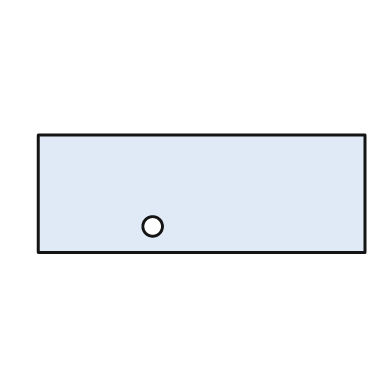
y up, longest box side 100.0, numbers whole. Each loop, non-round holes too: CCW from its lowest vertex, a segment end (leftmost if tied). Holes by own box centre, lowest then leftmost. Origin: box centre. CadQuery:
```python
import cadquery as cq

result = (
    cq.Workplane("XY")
    .moveTo(-50.0, -18.0)
    .lineTo(50.0, -18.0)
    .lineTo(50.0, 18.0)
    .lineTo(-50.0, 18.0)
    .close()
    .moveTo(-15.0, -10.0)
    .circle(3.0)
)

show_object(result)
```